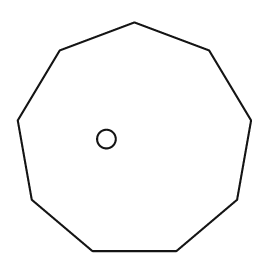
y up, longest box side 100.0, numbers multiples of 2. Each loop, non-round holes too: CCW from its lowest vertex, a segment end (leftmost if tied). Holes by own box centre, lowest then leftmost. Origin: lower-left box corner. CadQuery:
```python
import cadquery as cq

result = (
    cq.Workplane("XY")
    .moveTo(32.0, 0.0)
    .lineTo(68.0, 0.0)
    .lineTo(94.0, 22.0)
    .lineTo(100.0, 56.0)
    .lineTo(82.0, 86.0)
    .lineTo(50.0, 98.0)
    .lineTo(18.0, 86.0)
    .lineTo(0.0, 56.0)
    .lineTo(6.0, 22.0)
    .close()
    .moveTo(38.0, 48.0)
    .circle(4.0)
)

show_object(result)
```